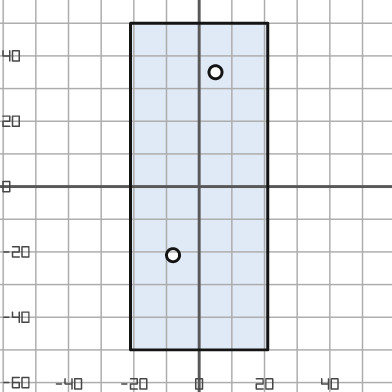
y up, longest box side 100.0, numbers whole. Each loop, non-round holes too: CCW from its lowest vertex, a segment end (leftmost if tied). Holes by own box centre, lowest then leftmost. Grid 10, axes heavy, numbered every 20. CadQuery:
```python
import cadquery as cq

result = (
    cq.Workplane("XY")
    .moveTo(-21.0, -50.0)
    .lineTo(21.0, -50.0)
    .lineTo(21.0, 50.0)
    .lineTo(-21.0, 50.0)
    .close()
    .moveTo(-8.0, -21.0)
    .circle(2.0)
    .moveTo(5.0, 35.0)
    .circle(2.0)
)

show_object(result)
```